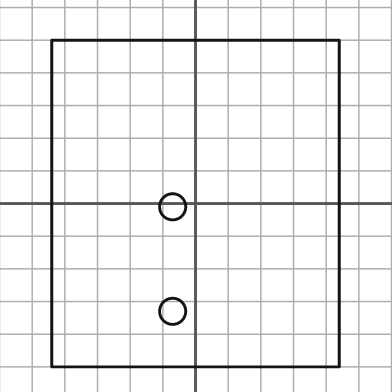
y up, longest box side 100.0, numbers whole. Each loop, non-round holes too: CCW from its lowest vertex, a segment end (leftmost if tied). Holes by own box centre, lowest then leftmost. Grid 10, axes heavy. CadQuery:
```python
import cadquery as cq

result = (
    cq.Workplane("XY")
    .moveTo(-44.0, -50.0)
    .lineTo(44.0, -50.0)
    .lineTo(44.0, 50.0)
    .lineTo(-44.0, 50.0)
    .close()
    .moveTo(-7.0, -33.0)
    .circle(4.0)
    .moveTo(-7.0, -1.0)
    .circle(4.0)
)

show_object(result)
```